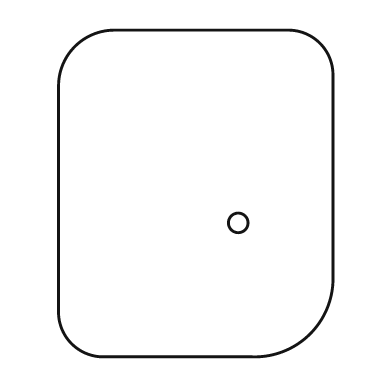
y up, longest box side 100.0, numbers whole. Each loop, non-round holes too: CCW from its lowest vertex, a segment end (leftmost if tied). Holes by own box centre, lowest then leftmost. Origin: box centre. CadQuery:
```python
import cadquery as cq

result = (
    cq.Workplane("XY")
    .moveTo(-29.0, -50.0)
    .lineTo(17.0, -50.0)
    .threePointArc((35.0, -43.0), (42.0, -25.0))
    .lineTo(42.0, 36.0)
    .threePointArc((38.0, 46.0), (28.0, 50.0))
    .lineTo(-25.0, 50.0)
    .threePointArc((-37.0, 45.0), (-42.0, 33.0))
    .lineTo(-42.0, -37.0)
    .threePointArc((-38.0, -46.0), (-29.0, -50.0))
    .close()
    .moveTo(13.0, -9.0)
    .circle(3.0)
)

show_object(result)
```